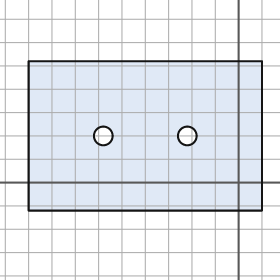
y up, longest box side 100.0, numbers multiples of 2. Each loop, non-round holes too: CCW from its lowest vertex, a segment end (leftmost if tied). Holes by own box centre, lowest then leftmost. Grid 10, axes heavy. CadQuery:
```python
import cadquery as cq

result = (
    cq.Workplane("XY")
    .moveTo(-90.0, -12.0)
    .lineTo(10.0, -12.0)
    .lineTo(10.0, 52.0)
    .lineTo(-90.0, 52.0)
    .close()
    .moveTo(-58.0, 20.0)
    .circle(4.0)
    .moveTo(-22.0, 20.0)
    .circle(4.0)
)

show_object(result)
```